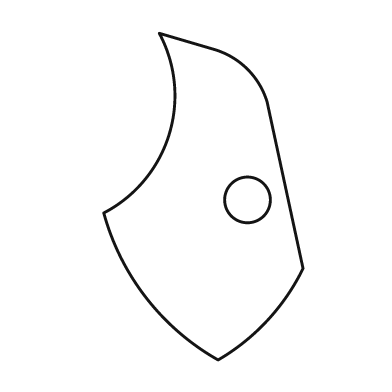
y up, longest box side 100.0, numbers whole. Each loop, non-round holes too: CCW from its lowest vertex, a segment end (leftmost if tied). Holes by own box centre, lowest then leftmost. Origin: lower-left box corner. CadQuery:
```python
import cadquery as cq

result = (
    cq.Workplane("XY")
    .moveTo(35.0, 0.0)
    .threePointArc((50.0, 12.0), (61.0, 28.0))
    .lineTo(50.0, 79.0)
    .threePointArc((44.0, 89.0), (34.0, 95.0))
    .lineTo(17.0, 100.0)
    .threePointArc((20.0, 69.0), (0.0, 45.0))
    .threePointArc((13.0, 19.0), (35.0, 0.0))
    .close()
    .moveTo(44.0, 49.0)
    .circle(7.0)
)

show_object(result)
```